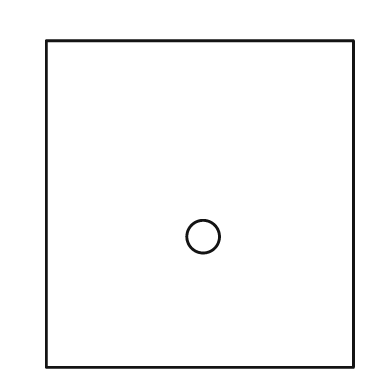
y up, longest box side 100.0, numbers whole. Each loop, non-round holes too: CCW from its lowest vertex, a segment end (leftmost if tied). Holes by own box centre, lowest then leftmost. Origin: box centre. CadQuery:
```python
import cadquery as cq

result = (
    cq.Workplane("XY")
    .moveTo(-47.0, -50.0)
    .lineTo(47.0, -50.0)
    .lineTo(47.0, 50.0)
    .lineTo(-47.0, 50.0)
    .close()
    .moveTo(1.0, -10.0)
    .circle(5.0)
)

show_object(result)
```